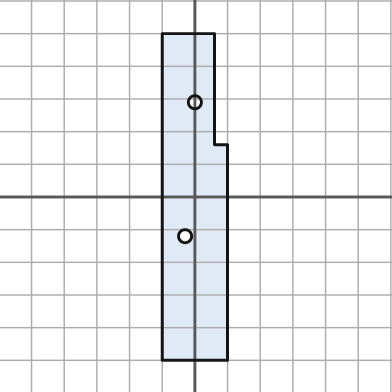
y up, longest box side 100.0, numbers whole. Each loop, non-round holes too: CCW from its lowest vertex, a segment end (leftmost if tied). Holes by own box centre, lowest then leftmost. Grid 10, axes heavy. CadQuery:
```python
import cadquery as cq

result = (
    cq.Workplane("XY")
    .moveTo(-10.0, -50.0)
    .lineTo(10.0, -50.0)
    .lineTo(10.0, 16.0)
    .lineTo(6.0, 16.0)
    .lineTo(6.0, 50.0)
    .lineTo(-10.0, 50.0)
    .close()
    .moveTo(-3.0, -12.0)
    .circle(2.0)
    .moveTo(0.0, 29.0)
    .circle(2.0)
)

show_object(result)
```